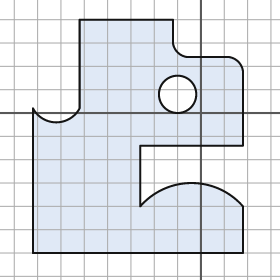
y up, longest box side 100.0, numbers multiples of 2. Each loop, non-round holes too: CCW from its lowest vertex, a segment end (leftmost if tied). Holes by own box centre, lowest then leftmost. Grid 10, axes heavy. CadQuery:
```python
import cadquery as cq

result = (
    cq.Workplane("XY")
    .moveTo(-72.0, -60.0)
    .lineTo(18.0, -60.0)
    .lineTo(18.0, -40.0)
    .threePointArc((-4.0, -30.0), (-26.0, -40.0))
    .lineTo(-26.0, -14.0)
    .lineTo(18.0, -14.0)
    .lineTo(18.0, 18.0)
    .threePointArc((16.0, 22.0), (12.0, 24.0))
    .lineTo(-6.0, 24.0)
    .threePointArc((-10.0, 26.0), (-12.0, 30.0))
    .lineTo(-12.0, 40.0)
    .lineTo(-52.0, 40.0)
    .lineTo(-52.0, 2.0)
    .threePointArc((-62.0, -4.0), (-72.0, 2.0))
    .close()
    .moveTo(-10.0, 8.0)
    .circle(8.0)
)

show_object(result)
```